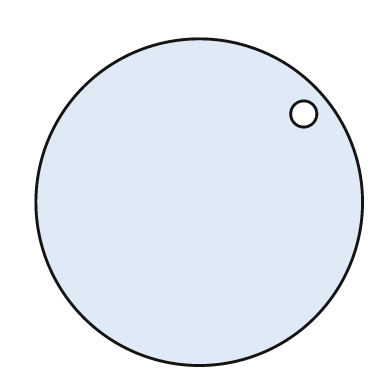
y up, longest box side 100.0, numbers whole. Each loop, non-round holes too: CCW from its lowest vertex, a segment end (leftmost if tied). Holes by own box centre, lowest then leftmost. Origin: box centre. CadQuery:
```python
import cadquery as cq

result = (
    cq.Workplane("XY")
    .moveTo(0.0, 0.0)
    .circle(50.0)
    .moveTo(32.0, 27.0)
    .circle(4.0)
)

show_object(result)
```